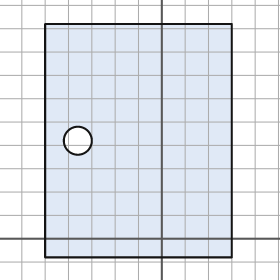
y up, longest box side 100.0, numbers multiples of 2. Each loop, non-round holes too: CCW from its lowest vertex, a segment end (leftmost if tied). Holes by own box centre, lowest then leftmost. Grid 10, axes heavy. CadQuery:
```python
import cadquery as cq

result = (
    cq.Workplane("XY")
    .moveTo(-50.0, -8.0)
    .lineTo(30.0, -8.0)
    .lineTo(30.0, 92.0)
    .lineTo(-50.0, 92.0)
    .close()
    .moveTo(-36.0, 42.0)
    .circle(6.0)
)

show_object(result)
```